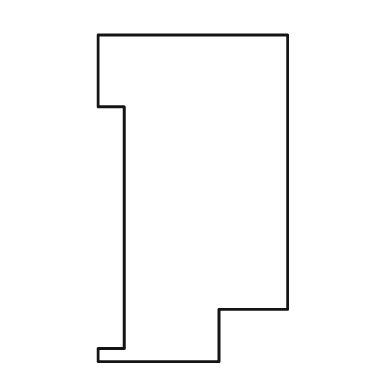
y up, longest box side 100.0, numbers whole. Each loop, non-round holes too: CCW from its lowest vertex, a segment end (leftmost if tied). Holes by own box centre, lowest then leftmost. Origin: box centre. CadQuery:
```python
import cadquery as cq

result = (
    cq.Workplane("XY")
    .moveTo(-29.0, -50.0)
    .lineTo(8.0, -50.0)
    .lineTo(8.0, -34.0)
    .lineTo(29.0, -34.0)
    .lineTo(29.0, 50.0)
    .lineTo(-29.0, 50.0)
    .lineTo(-29.0, 28.0)
    .lineTo(-21.0, 28.0)
    .lineTo(-21.0, -46.0)
    .lineTo(-29.0, -46.0)
    .close()
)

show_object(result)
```